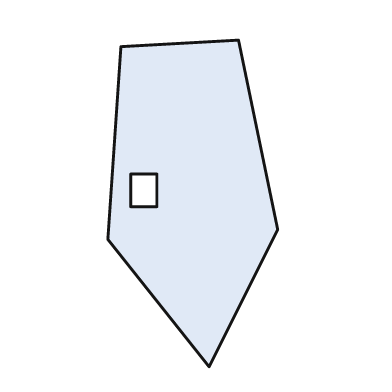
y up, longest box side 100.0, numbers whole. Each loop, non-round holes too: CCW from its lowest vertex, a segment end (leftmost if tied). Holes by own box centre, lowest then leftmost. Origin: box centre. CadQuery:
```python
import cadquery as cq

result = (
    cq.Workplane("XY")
    .moveTo(5.0, -50.0)
    .lineTo(26.0, -8.0)
    .lineTo(14.0, 50.0)
    .lineTo(-22.0, 48.0)
    .lineTo(-26.0, -11.0)
    .close()
    .moveTo(-19.0, -1.0)
    .lineTo(-11.0, -1.0)
    .lineTo(-11.0, 9.0)
    .lineTo(-19.0, 9.0)
    .close()
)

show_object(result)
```